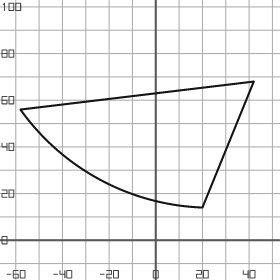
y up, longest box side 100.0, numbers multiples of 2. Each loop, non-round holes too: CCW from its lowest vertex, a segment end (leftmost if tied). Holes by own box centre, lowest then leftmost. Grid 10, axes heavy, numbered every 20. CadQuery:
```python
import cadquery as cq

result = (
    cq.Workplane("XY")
    .moveTo(20.0, 14.0)
    .lineTo(42.0, 68.0)
    .lineTo(-58.0, 56.0)
    .threePointArc((-24.0, 26.0), (20.0, 14.0))
    .close()
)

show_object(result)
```